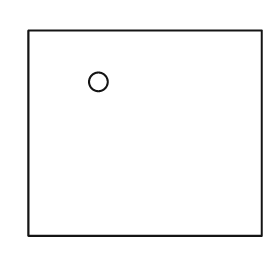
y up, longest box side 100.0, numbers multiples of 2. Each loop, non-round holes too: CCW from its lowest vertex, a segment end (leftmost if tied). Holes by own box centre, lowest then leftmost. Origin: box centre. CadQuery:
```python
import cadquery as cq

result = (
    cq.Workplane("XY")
    .moveTo(-50.0, -44.0)
    .lineTo(50.0, -44.0)
    .lineTo(50.0, 44.0)
    .lineTo(-50.0, 44.0)
    .close()
    .moveTo(-20.0, 22.0)
    .circle(4.0)
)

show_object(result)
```